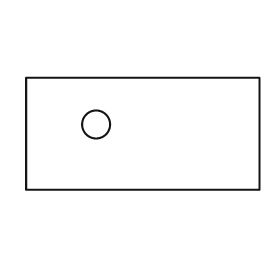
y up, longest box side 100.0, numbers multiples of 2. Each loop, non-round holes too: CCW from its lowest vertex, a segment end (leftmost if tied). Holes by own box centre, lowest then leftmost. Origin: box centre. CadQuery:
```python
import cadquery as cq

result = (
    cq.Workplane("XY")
    .moveTo(-50.0, -24.0)
    .lineTo(50.0, -24.0)
    .lineTo(50.0, 24.0)
    .lineTo(-50.0, 24.0)
    .close()
    .moveTo(-20.0, 4.0)
    .circle(6.0)
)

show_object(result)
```